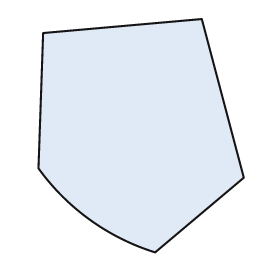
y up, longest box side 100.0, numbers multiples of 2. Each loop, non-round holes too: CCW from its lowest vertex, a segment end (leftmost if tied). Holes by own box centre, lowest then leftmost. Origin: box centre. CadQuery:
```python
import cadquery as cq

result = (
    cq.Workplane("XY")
    .moveTo(6.0, -50.0)
    .lineTo(44.0, -18.0)
    .lineTo(26.0, 50.0)
    .lineTo(-42.0, 44.0)
    .lineTo(-44.0, -14.0)
    .threePointArc((-22.0, -36.0), (6.0, -50.0))
    .close()
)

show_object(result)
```